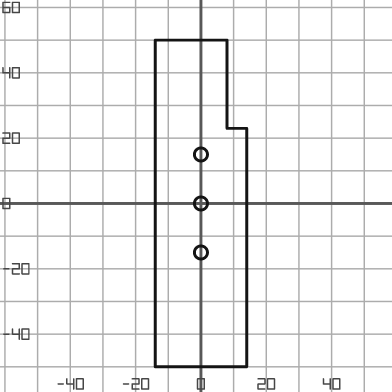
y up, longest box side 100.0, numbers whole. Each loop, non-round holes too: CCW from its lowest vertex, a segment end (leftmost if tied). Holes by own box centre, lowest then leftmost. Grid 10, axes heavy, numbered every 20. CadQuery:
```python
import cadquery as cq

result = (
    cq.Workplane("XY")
    .moveTo(-14.0, -50.0)
    .lineTo(14.0, -50.0)
    .lineTo(14.0, 23.0)
    .lineTo(8.0, 23.0)
    .lineTo(8.0, 50.0)
    .lineTo(-14.0, 50.0)
    .close()
    .moveTo(0.0, -15.0)
    .circle(2.0)
    .moveTo(0.0, 0.0)
    .circle(2.0)
    .moveTo(0.0, 15.0)
    .circle(2.0)
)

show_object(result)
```